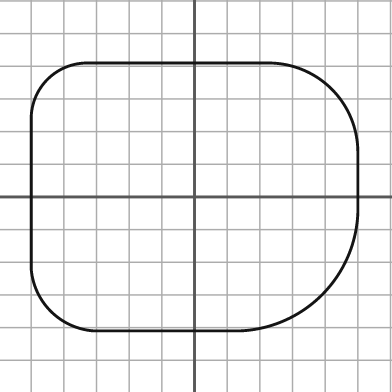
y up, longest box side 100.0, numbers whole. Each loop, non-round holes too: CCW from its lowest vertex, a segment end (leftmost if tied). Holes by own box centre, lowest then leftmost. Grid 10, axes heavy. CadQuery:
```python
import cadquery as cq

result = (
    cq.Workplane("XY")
    .moveTo(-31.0, -41.0)
    .lineTo(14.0, -41.0)
    .threePointArc((39.0, -30.0), (50.0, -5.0))
    .lineTo(50.0, 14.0)
    .threePointArc((42.0, 33.0), (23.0, 41.0))
    .lineTo(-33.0, 41.0)
    .threePointArc((-45.0, 36.0), (-50.0, 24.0))
    .lineTo(-50.0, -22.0)
    .threePointArc((-44.0, -35.0), (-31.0, -41.0))
    .close()
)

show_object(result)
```